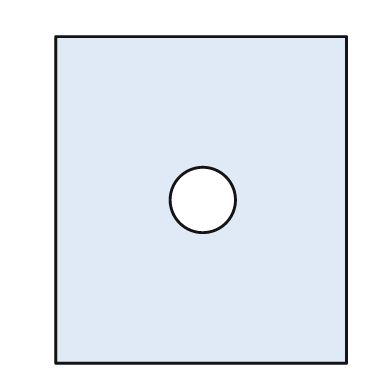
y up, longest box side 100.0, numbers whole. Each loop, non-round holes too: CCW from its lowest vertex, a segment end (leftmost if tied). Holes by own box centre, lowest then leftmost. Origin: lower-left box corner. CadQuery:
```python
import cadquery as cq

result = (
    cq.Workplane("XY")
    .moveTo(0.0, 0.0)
    .lineTo(89.0, 0.0)
    .lineTo(89.0, 100.0)
    .lineTo(0.0, 100.0)
    .close()
    .moveTo(45.0, 50.0)
    .circle(10.0)
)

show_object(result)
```